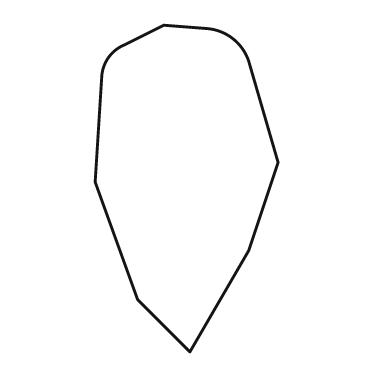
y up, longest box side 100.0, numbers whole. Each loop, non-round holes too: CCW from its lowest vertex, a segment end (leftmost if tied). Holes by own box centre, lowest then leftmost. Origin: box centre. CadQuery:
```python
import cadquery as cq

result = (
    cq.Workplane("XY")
    .moveTo(1.0, -50.0)
    .lineTo(19.0, -19.0)
    .lineTo(28.0, 8.0)
    .lineTo(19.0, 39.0)
    .threePointArc((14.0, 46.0), (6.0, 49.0))
    .lineTo(-7.0, 50.0)
    .lineTo(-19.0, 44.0)
    .threePointArc((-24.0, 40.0), (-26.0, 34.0))
    .lineTo(-28.0, 2.0)
    .lineTo(-15.0, -34.0)
    .close()
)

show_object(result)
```